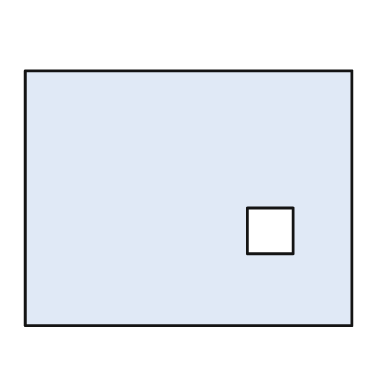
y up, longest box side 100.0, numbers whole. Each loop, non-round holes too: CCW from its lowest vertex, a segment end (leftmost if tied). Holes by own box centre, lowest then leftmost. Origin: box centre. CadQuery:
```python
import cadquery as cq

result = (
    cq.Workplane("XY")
    .moveTo(-50.0, -39.0)
    .lineTo(50.0, -39.0)
    .lineTo(50.0, 39.0)
    .lineTo(-50.0, 39.0)
    .close()
    .moveTo(18.0, -17.0)
    .lineTo(32.0, -17.0)
    .lineTo(32.0, -3.0)
    .lineTo(18.0, -3.0)
    .close()
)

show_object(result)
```